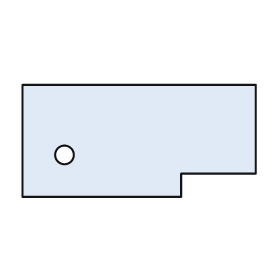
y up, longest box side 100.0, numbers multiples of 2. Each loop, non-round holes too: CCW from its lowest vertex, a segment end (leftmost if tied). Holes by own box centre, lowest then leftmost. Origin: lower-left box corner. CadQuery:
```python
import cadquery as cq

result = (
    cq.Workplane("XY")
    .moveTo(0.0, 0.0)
    .lineTo(68.0, 0.0)
    .lineTo(68.0, 10.0)
    .lineTo(100.0, 10.0)
    .lineTo(100.0, 48.0)
    .lineTo(0.0, 48.0)
    .close()
    .moveTo(18.0, 18.0)
    .circle(4.0)
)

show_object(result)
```